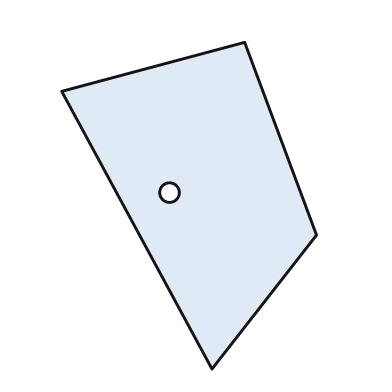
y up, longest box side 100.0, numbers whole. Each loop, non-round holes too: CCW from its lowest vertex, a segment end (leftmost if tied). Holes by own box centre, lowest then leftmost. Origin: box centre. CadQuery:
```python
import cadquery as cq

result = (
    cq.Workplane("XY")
    .moveTo(7.0, -50.0)
    .lineTo(39.0, -9.0)
    .lineTo(17.0, 50.0)
    .lineTo(-39.0, 35.0)
    .close()
    .moveTo(-6.0, 4.0)
    .circle(3.0)
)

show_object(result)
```